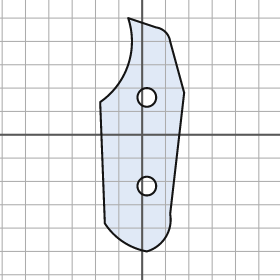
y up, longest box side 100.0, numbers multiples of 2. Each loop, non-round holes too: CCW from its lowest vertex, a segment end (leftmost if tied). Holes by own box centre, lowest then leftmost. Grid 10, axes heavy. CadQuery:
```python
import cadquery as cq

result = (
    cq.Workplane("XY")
    .moveTo(2.0, -50.0)
    .threePointArc((10.0, -44.0), (12.0, -34.0))
    .lineTo(18.0, 18.0)
    .lineTo(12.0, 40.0)
    .threePointArc((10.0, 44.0), (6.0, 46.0))
    .lineTo(-6.0, 50.0)
    .threePointArc((-6.0, 30.0), (-18.0, 14.0))
    .lineTo(-16.0, -38.0)
    .threePointArc((-8.0, -46.0), (2.0, -50.0))
    .close()
    .moveTo(2.0, -22.0)
    .circle(4.0)
    .moveTo(2.0, 16.0)
    .circle(4.0)
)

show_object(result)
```